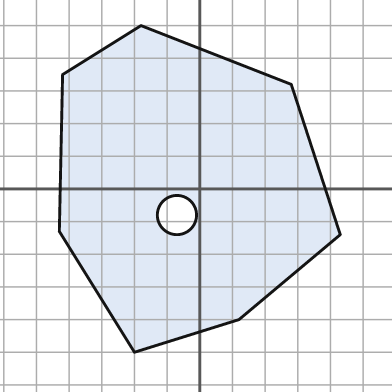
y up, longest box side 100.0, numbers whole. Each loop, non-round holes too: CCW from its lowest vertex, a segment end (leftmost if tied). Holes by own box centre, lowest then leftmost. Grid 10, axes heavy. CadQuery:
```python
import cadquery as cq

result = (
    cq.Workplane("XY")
    .moveTo(-20.0, -50.0)
    .lineTo(12.0, -40.0)
    .lineTo(43.0, -14.0)
    .lineTo(28.0, 32.0)
    .lineTo(-18.0, 50.0)
    .lineTo(-42.0, 35.0)
    .lineTo(-43.0, -13.0)
    .close()
    .moveTo(-7.0, -8.0)
    .circle(6.0)
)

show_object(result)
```